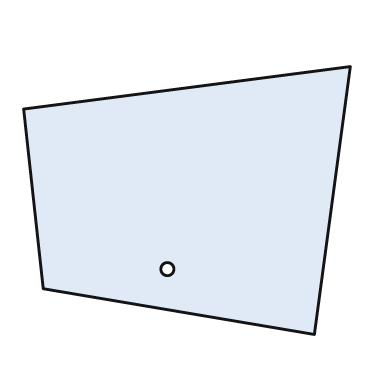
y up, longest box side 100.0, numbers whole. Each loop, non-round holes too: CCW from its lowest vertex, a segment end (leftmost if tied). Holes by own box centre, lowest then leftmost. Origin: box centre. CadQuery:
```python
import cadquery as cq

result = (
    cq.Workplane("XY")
    .moveTo(39.0, -41.0)
    .lineTo(50.0, 41.0)
    .lineTo(-50.0, 28.0)
    .lineTo(-44.0, -27.0)
    .close()
    .moveTo(-6.0, -21.0)
    .circle(2.0)
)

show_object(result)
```